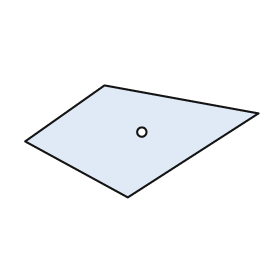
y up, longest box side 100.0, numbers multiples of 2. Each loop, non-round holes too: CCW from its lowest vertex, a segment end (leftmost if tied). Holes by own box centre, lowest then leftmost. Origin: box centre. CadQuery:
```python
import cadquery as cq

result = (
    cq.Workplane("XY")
    .moveTo(-6.0, -24.0)
    .lineTo(50.0, 12.0)
    .lineTo(-16.0, 24.0)
    .lineTo(-50.0, 0.0)
    .close()
    .moveTo(0.0, 4.0)
    .circle(2.0)
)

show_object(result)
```